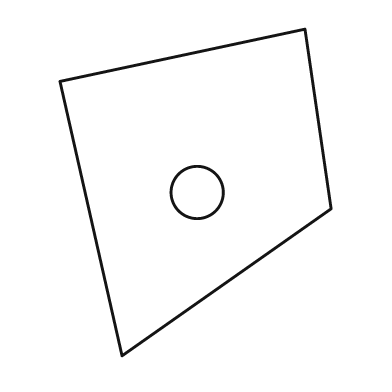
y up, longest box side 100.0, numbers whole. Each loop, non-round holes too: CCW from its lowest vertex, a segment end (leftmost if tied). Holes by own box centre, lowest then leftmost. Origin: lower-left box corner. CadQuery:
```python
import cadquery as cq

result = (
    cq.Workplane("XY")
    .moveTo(19.0, 0.0)
    .lineTo(83.0, 45.0)
    .lineTo(75.0, 100.0)
    .lineTo(0.0, 84.0)
    .close()
    .moveTo(42.0, 50.0)
    .circle(8.0)
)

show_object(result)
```